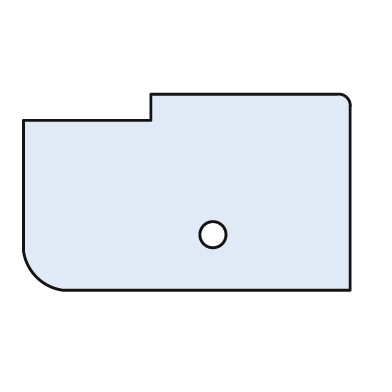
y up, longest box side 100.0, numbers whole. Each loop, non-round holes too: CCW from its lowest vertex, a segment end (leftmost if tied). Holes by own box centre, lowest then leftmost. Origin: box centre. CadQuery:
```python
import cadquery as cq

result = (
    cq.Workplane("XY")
    .moveTo(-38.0, -30.0)
    .lineTo(50.0, -30.0)
    .lineTo(50.0, 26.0)
    .threePointArc((49.0, 29.0), (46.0, 30.0))
    .lineTo(-11.0, 30.0)
    .lineTo(-11.0, 22.0)
    .lineTo(-50.0, 22.0)
    .lineTo(-50.0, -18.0)
    .threePointArc((-46.0, -26.0), (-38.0, -30.0))
    .close()
    .moveTo(8.0, -13.0)
    .circle(4.0)
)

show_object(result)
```